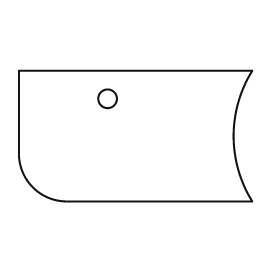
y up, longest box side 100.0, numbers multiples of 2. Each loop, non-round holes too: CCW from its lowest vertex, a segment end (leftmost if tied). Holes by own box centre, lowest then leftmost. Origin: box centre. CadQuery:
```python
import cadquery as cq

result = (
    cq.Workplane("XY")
    .moveTo(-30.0, -28.0)
    .lineTo(50.0, -28.0)
    .threePointArc((42.0, 0.0), (50.0, 28.0))
    .lineTo(-50.0, 28.0)
    .lineTo(-50.0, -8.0)
    .threePointArc((-44.0, -22.0), (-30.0, -28.0))
    .close()
    .moveTo(-12.0, 16.0)
    .circle(4.0)
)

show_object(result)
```